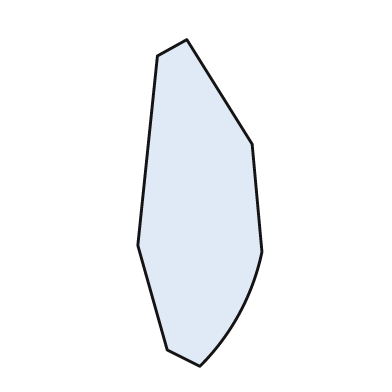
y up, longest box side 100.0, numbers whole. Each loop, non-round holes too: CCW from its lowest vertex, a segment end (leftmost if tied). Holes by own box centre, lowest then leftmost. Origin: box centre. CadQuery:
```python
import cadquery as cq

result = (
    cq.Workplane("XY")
    .moveTo(0.0, -50.0)
    .threePointArc((12.0, -34.0), (19.0, -15.0))
    .lineTo(16.0, 18.0)
    .lineTo(-4.0, 50.0)
    .lineTo(-13.0, 45.0)
    .lineTo(-19.0, -13.0)
    .lineTo(-10.0, -45.0)
    .close()
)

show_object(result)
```